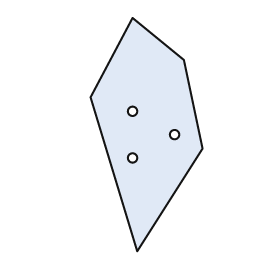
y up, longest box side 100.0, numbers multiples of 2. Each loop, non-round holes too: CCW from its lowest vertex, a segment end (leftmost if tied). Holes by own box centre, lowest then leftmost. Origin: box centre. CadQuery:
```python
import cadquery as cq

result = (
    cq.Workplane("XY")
    .moveTo(-4.0, -50.0)
    .lineTo(24.0, -6.0)
    .lineTo(16.0, 32.0)
    .lineTo(-6.0, 50.0)
    .lineTo(-24.0, 16.0)
    .close()
    .moveTo(-6.0, -10.0)
    .circle(2.0)
    .moveTo(12.0, 0.0)
    .circle(2.0)
    .moveTo(-6.0, 10.0)
    .circle(2.0)
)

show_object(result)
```